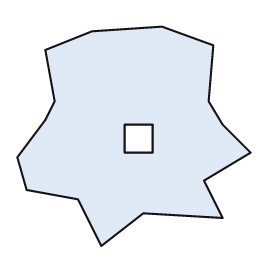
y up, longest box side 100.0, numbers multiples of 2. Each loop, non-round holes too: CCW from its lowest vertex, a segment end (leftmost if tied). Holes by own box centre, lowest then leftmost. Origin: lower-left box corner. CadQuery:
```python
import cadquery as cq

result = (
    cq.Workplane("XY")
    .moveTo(36.0, 0.0)
    .lineTo(54.0, 14.0)
    .lineTo(88.0, 12.0)
    .lineTo(80.0, 28.0)
    .lineTo(100.0, 40.0)
    .lineTo(88.0, 52.0)
    .lineTo(82.0, 62.0)
    .lineTo(84.0, 86.0)
    .lineTo(62.0, 94.0)
    .lineTo(32.0, 92.0)
    .lineTo(12.0, 84.0)
    .lineTo(16.0, 62.0)
    .lineTo(12.0, 54.0)
    .lineTo(0.0, 38.0)
    .lineTo(4.0, 24.0)
    .lineTo(26.0, 20.0)
    .close()
    .moveTo(46.0, 40.0)
    .lineTo(58.0, 40.0)
    .lineTo(58.0, 52.0)
    .lineTo(46.0, 52.0)
    .close()
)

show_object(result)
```